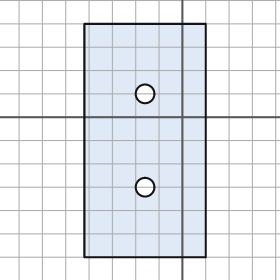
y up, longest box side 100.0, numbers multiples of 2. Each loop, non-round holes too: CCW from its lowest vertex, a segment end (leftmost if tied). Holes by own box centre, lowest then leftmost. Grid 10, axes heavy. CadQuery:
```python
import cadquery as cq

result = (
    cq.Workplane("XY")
    .moveTo(-42.0, -60.0)
    .lineTo(10.0, -60.0)
    .lineTo(10.0, 40.0)
    .lineTo(-42.0, 40.0)
    .close()
    .moveTo(-16.0, -30.0)
    .circle(4.0)
    .moveTo(-16.0, 10.0)
    .circle(4.0)
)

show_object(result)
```